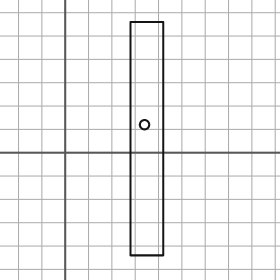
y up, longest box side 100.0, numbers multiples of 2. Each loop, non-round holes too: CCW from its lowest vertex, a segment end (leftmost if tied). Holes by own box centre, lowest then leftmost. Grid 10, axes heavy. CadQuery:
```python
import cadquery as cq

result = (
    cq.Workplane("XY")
    .moveTo(28.0, -44.0)
    .lineTo(42.0, -44.0)
    .lineTo(42.0, 56.0)
    .lineTo(28.0, 56.0)
    .close()
    .moveTo(34.0, 12.0)
    .circle(2.0)
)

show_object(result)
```